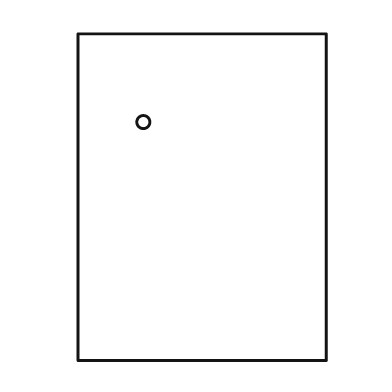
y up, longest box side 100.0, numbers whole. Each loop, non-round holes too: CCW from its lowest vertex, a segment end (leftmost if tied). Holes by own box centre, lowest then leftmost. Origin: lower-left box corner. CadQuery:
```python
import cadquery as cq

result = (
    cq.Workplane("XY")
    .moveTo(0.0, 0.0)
    .lineTo(76.0, 0.0)
    .lineTo(76.0, 100.0)
    .lineTo(0.0, 100.0)
    .close()
    .moveTo(20.0, 73.0)
    .circle(2.0)
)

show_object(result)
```